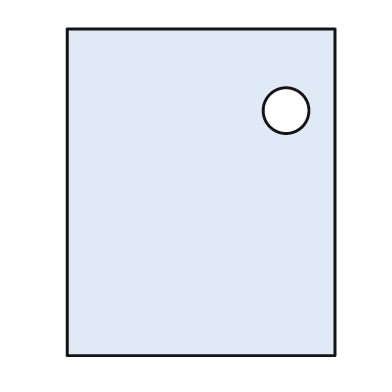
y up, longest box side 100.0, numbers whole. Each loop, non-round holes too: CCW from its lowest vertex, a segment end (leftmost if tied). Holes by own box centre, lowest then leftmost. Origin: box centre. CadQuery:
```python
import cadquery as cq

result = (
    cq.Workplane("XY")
    .moveTo(-41.0, -50.0)
    .lineTo(41.0, -50.0)
    .lineTo(41.0, 50.0)
    .lineTo(-41.0, 50.0)
    .close()
    .moveTo(26.0, 25.0)
    .circle(7.0)
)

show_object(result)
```